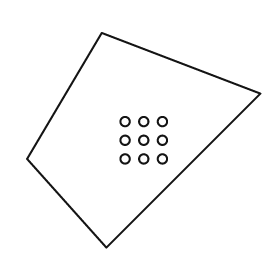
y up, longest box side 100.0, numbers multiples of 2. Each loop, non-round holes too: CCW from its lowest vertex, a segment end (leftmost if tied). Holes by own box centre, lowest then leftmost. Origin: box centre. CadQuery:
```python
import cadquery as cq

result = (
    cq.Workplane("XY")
    .moveTo(-16.0, -46.0)
    .lineTo(50.0, 20.0)
    .lineTo(-18.0, 46.0)
    .lineTo(-50.0, -8.0)
    .close()
    .moveTo(-8.0, -8.0)
    .circle(2.0)
    .moveTo(0.0, -8.0)
    .circle(2.0)
    .moveTo(8.0, -8.0)
    .circle(2.0)
    .moveTo(-8.0, 0.0)
    .circle(2.0)
    .moveTo(0.0, 0.0)
    .circle(2.0)
    .moveTo(8.0, 0.0)
    .circle(2.0)
    .moveTo(-8.0, 8.0)
    .circle(2.0)
    .moveTo(0.0, 8.0)
    .circle(2.0)
    .moveTo(8.0, 8.0)
    .circle(2.0)
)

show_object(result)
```